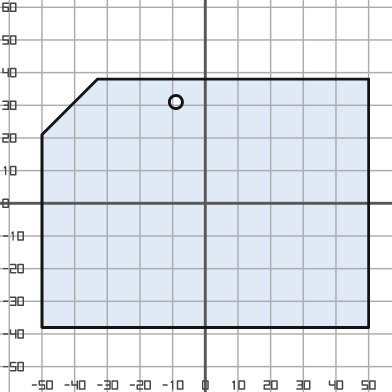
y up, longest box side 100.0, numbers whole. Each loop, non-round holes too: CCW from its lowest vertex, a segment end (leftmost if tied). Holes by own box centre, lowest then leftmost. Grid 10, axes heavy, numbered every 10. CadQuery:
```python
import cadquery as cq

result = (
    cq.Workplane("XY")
    .moveTo(-50.0, -38.0)
    .lineTo(50.0, -38.0)
    .lineTo(50.0, 38.0)
    .lineTo(-33.0, 38.0)
    .lineTo(-50.0, 21.0)
    .close()
    .moveTo(-9.0, 31.0)
    .circle(2.0)
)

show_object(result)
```